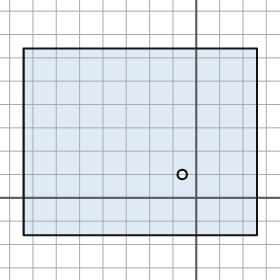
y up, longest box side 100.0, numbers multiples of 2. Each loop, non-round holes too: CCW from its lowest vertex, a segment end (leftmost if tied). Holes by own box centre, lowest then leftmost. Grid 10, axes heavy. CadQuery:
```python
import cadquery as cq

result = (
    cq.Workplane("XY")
    .moveTo(-74.0, -16.0)
    .lineTo(26.0, -16.0)
    .lineTo(26.0, 64.0)
    .lineTo(-74.0, 64.0)
    .close()
    .moveTo(-6.0, 10.0)
    .circle(2.0)
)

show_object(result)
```